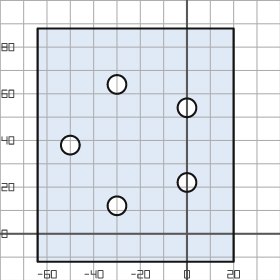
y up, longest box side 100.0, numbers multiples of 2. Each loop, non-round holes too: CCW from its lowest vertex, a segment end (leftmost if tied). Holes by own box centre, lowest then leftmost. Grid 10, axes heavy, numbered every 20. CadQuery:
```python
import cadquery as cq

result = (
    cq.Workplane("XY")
    .moveTo(-64.0, -12.0)
    .lineTo(20.0, -12.0)
    .lineTo(20.0, 88.0)
    .lineTo(-64.0, 88.0)
    .close()
    .moveTo(-30.0, 12.0)
    .circle(4.0)
    .moveTo(0.0, 22.0)
    .circle(4.0)
    .moveTo(-50.0, 38.0)
    .circle(4.0)
    .moveTo(0.0, 54.0)
    .circle(4.0)
    .moveTo(-30.0, 64.0)
    .circle(4.0)
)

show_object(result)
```